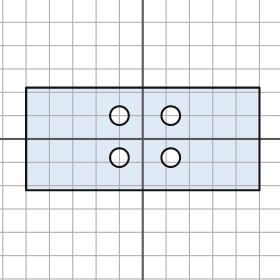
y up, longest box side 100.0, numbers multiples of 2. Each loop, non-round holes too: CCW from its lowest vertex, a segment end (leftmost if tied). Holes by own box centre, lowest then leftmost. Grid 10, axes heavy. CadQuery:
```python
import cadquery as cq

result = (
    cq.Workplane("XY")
    .moveTo(-50.0, -22.0)
    .lineTo(50.0, -22.0)
    .lineTo(50.0, 22.0)
    .lineTo(-50.0, 22.0)
    .close()
    .moveTo(-10.0, -8.0)
    .circle(4.0)
    .moveTo(12.0, -8.0)
    .circle(4.0)
    .moveTo(-10.0, 10.0)
    .circle(4.0)
    .moveTo(12.0, 10.0)
    .circle(4.0)
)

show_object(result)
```